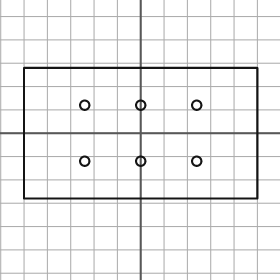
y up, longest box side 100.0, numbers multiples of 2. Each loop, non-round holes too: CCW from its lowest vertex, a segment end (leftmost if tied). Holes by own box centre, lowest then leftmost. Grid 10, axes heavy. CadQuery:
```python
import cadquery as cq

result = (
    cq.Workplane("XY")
    .moveTo(-50.0, -28.0)
    .lineTo(50.0, -28.0)
    .lineTo(50.0, 28.0)
    .lineTo(-50.0, 28.0)
    .close()
    .moveTo(-24.0, -12.0)
    .circle(2.0)
    .moveTo(0.0, -12.0)
    .circle(2.0)
    .moveTo(24.0, -12.0)
    .circle(2.0)
    .moveTo(-24.0, 12.0)
    .circle(2.0)
    .moveTo(0.0, 12.0)
    .circle(2.0)
    .moveTo(24.0, 12.0)
    .circle(2.0)
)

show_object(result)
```